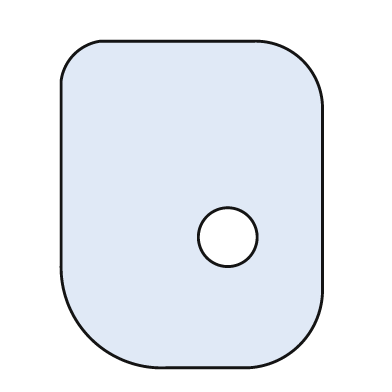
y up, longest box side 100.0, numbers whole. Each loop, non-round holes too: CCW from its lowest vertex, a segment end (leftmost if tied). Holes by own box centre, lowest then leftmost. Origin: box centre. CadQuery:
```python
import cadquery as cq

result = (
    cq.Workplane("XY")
    .moveTo(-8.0, -50.0)
    .lineTo(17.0, -50.0)
    .threePointArc((33.0, -43.0), (40.0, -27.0))
    .lineTo(40.0, 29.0)
    .threePointArc((34.0, 44.0), (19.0, 50.0))
    .lineTo(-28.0, 50.0)
    .threePointArc((-36.0, 46.0), (-40.0, 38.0))
    .lineTo(-40.0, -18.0)
    .threePointArc((-31.0, -41.0), (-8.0, -50.0))
    .close()
    .moveTo(11.0, -10.0)
    .circle(9.0)
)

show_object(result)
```